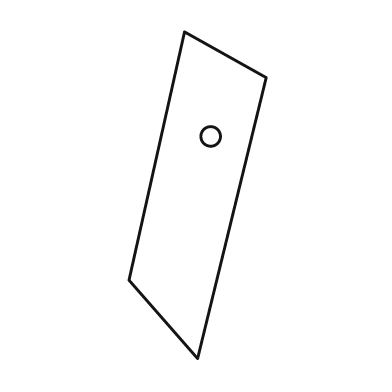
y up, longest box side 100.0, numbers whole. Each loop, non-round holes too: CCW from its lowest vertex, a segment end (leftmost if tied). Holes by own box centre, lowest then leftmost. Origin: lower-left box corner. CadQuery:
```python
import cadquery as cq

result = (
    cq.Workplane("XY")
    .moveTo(21.0, 0.0)
    .lineTo(42.0, 86.0)
    .lineTo(17.0, 100.0)
    .lineTo(0.0, 24.0)
    .close()
    .moveTo(25.0, 68.0)
    .circle(3.0)
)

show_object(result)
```